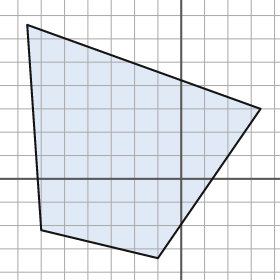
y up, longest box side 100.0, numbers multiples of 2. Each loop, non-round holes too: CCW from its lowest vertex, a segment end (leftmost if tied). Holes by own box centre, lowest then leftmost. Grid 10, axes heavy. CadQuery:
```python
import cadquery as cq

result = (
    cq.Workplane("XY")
    .moveTo(-10.0, -34.0)
    .lineTo(34.0, 30.0)
    .lineTo(-66.0, 66.0)
    .lineTo(-60.0, -22.0)
    .close()
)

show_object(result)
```